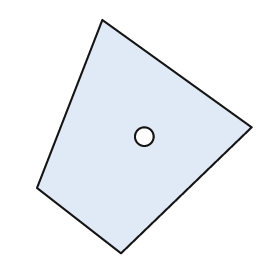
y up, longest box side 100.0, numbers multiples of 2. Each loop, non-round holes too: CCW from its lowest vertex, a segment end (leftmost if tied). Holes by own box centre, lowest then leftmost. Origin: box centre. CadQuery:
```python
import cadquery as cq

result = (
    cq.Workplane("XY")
    .moveTo(-10.0, -50.0)
    .lineTo(46.0, 4.0)
    .lineTo(-18.0, 50.0)
    .lineTo(-46.0, -22.0)
    .close()
    .moveTo(0.0, 0.0)
    .circle(4.0)
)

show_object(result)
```